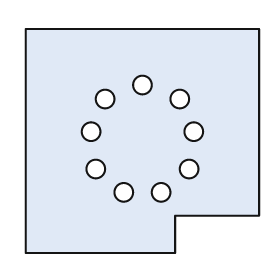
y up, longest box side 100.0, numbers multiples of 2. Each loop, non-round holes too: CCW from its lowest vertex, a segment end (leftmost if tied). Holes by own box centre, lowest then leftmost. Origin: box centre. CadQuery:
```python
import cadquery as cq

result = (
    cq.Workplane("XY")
    .moveTo(-50.0, -48.0)
    .lineTo(14.0, -48.0)
    .lineTo(14.0, -32.0)
    .lineTo(50.0, -32.0)
    .lineTo(50.0, 48.0)
    .lineTo(-50.0, 48.0)
    .close()
    .moveTo(-8.0, -22.0)
    .circle(4.0)
    .moveTo(8.0, -22.0)
    .circle(4.0)
    .moveTo(-20.0, -12.0)
    .circle(4.0)
    .moveTo(20.0, -12.0)
    .circle(4.0)
    .moveTo(-22.0, 4.0)
    .circle(4.0)
    .moveTo(22.0, 4.0)
    .circle(4.0)
    .moveTo(-16.0, 18.0)
    .circle(4.0)
    .moveTo(16.0, 18.0)
    .circle(4.0)
    .moveTo(0.0, 24.0)
    .circle(4.0)
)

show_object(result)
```